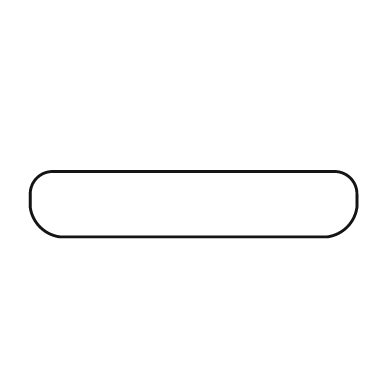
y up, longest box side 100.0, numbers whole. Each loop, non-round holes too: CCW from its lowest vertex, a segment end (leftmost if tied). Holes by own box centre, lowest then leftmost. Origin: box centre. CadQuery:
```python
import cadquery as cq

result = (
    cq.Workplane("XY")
    .moveTo(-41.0, -10.0)
    .lineTo(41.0, -10.0)
    .threePointArc((47.0, -7.0), (50.0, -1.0))
    .lineTo(50.0, 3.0)
    .threePointArc((48.0, 8.0), (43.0, 10.0))
    .lineTo(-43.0, 10.0)
    .threePointArc((-48.0, 8.0), (-50.0, 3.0))
    .lineTo(-50.0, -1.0)
    .threePointArc((-47.0, -7.0), (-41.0, -10.0))
    .close()
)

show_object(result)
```